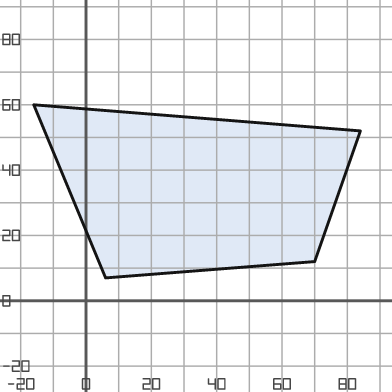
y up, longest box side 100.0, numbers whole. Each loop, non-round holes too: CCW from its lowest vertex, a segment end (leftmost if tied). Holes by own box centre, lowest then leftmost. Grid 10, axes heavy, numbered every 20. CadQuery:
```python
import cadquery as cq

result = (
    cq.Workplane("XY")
    .moveTo(6.0, 7.0)
    .lineTo(70.0, 12.0)
    .lineTo(84.0, 52.0)
    .lineTo(-16.0, 60.0)
    .close()
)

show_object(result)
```